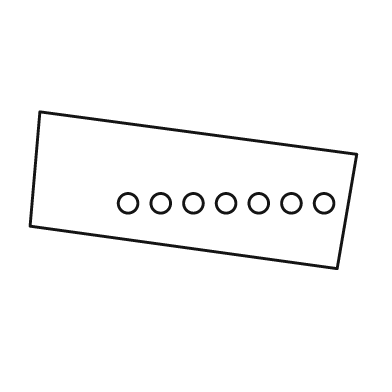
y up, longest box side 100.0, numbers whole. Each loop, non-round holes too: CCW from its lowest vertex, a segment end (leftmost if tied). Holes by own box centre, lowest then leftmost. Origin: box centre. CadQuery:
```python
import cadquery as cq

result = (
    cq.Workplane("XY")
    .moveTo(44.0, -24.0)
    .lineTo(50.0, 11.0)
    .lineTo(-47.0, 24.0)
    .lineTo(-50.0, -11.0)
    .close()
    .moveTo(-20.0, -4.0)
    .circle(3.0)
    .moveTo(-10.0, -4.0)
    .circle(3.0)
    .moveTo(0.0, -4.0)
    .circle(3.0)
    .moveTo(10.0, -4.0)
    .circle(3.0)
    .moveTo(20.0, -4.0)
    .circle(3.0)
    .moveTo(30.0, -4.0)
    .circle(3.0)
    .moveTo(40.0, -4.0)
    .circle(3.0)
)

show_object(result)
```